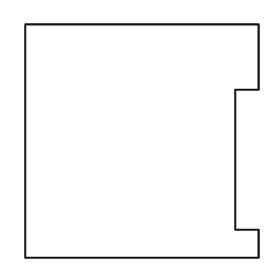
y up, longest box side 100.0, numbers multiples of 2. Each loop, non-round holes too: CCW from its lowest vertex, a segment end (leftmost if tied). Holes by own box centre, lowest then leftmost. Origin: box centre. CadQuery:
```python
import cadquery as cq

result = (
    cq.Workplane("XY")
    .moveTo(-50.0, -50.0)
    .lineTo(50.0, -50.0)
    .lineTo(50.0, -38.0)
    .lineTo(40.0, -38.0)
    .lineTo(40.0, 22.0)
    .lineTo(50.0, 22.0)
    .lineTo(50.0, 50.0)
    .lineTo(-50.0, 50.0)
    .close()
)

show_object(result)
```